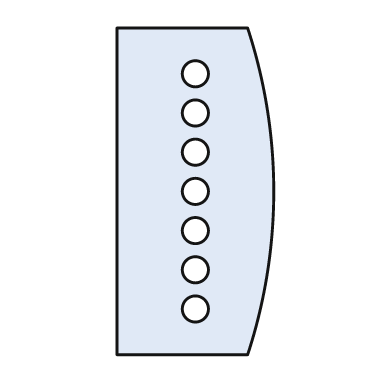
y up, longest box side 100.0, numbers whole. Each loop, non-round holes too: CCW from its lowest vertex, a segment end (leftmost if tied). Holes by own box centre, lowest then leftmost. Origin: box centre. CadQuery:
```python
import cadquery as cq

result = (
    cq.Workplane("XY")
    .moveTo(-24.0, -50.0)
    .lineTo(16.0, -50.0)
    .threePointArc((24.0, 0.0), (16.0, 50.0))
    .lineTo(-24.0, 50.0)
    .close()
    .moveTo(0.0, -36.0)
    .circle(4.0)
    .moveTo(0.0, -24.0)
    .circle(4.0)
    .moveTo(0.0, -12.0)
    .circle(4.0)
    .moveTo(0.0, 0.0)
    .circle(4.0)
    .moveTo(0.0, 12.0)
    .circle(4.0)
    .moveTo(0.0, 24.0)
    .circle(4.0)
    .moveTo(0.0, 36.0)
    .circle(4.0)
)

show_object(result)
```